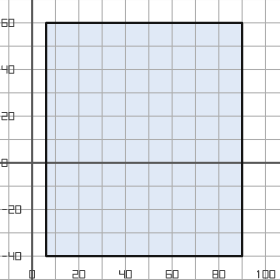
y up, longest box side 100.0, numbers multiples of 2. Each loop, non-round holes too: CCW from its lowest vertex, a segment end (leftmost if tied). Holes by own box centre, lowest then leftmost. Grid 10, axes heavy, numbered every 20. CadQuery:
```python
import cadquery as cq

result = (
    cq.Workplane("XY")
    .moveTo(6.0, -40.0)
    .lineTo(90.0, -40.0)
    .lineTo(90.0, 60.0)
    .lineTo(6.0, 60.0)
    .close()
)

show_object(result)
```